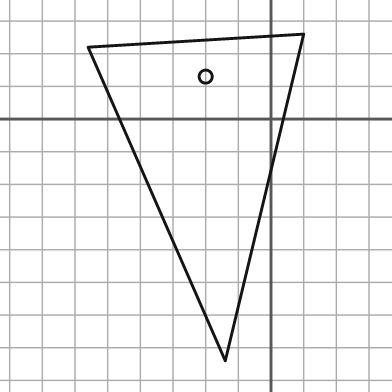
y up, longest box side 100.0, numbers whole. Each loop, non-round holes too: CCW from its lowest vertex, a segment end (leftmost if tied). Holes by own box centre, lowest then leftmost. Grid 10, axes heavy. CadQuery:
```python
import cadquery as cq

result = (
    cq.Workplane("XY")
    .moveTo(-14.0, -74.0)
    .lineTo(10.0, 26.0)
    .lineTo(-56.0, 22.0)
    .close()
    .moveTo(-20.0, 13.0)
    .circle(2.0)
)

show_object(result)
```